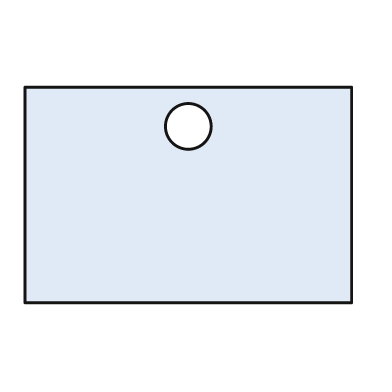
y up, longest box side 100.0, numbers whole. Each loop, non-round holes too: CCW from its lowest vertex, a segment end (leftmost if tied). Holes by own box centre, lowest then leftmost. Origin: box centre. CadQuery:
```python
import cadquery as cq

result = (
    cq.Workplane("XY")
    .moveTo(-50.0, -33.0)
    .lineTo(50.0, -33.0)
    .lineTo(50.0, 33.0)
    .lineTo(-50.0, 33.0)
    .close()
    .moveTo(0.0, 21.0)
    .circle(7.0)
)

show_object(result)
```